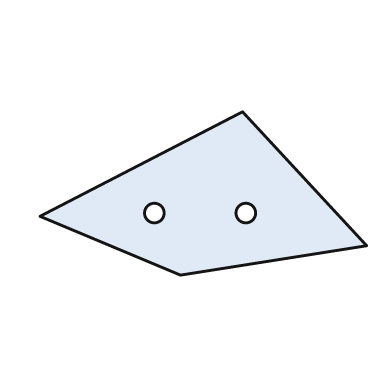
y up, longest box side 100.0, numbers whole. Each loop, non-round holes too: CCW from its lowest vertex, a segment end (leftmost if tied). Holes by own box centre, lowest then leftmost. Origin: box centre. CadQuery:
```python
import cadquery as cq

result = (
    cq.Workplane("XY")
    .moveTo(-7.0, -25.0)
    .lineTo(50.0, -16.0)
    .lineTo(12.0, 25.0)
    .lineTo(-50.0, -7.0)
    .close()
    .moveTo(-15.0, -6.0)
    .circle(3.0)
    .moveTo(13.0, -6.0)
    .circle(3.0)
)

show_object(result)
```